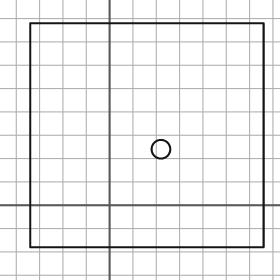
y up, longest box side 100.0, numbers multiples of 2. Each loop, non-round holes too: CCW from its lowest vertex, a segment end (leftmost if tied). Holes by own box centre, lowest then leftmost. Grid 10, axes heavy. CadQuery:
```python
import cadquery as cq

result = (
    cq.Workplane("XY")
    .moveTo(-34.0, -18.0)
    .lineTo(66.0, -18.0)
    .lineTo(66.0, 78.0)
    .lineTo(-34.0, 78.0)
    .close()
    .moveTo(22.0, 24.0)
    .circle(4.0)
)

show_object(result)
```